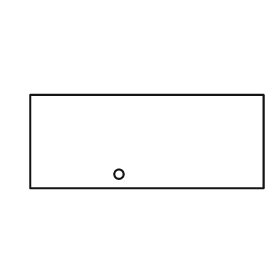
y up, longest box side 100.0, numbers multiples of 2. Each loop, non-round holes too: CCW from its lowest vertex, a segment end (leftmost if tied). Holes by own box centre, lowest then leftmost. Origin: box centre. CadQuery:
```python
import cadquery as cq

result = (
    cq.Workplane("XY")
    .moveTo(-50.0, -20.0)
    .lineTo(50.0, -20.0)
    .lineTo(50.0, 20.0)
    .lineTo(-50.0, 20.0)
    .close()
    .moveTo(-12.0, -14.0)
    .circle(2.0)
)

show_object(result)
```